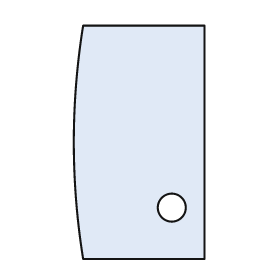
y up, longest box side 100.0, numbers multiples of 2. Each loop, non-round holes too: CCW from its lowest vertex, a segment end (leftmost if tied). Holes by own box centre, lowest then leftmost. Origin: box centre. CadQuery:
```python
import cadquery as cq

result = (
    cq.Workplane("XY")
    .moveTo(-24.0, -50.0)
    .lineTo(28.0, -50.0)
    .lineTo(28.0, 50.0)
    .lineTo(-24.0, 50.0)
    .threePointArc((-28.0, 0.0), (-24.0, -50.0))
    .close()
    .moveTo(14.0, -28.0)
    .circle(6.0)
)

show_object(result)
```